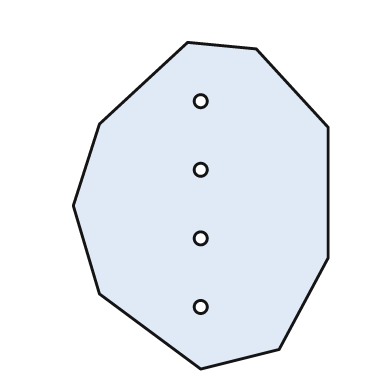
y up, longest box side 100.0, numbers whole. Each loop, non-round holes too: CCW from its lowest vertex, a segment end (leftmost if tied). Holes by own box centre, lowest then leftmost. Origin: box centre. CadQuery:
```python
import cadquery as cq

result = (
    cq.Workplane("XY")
    .moveTo(0.0, -50.0)
    .lineTo(24.0, -44.0)
    .lineTo(39.0, -16.0)
    .lineTo(39.0, 24.0)
    .lineTo(17.0, 48.0)
    .lineTo(-4.0, 50.0)
    .lineTo(-31.0, 25.0)
    .lineTo(-39.0, 0.0)
    .lineTo(-31.0, -27.0)
    .close()
    .moveTo(0.0, -31.0)
    .circle(2.0)
    .moveTo(0.0, -10.0)
    .circle(2.0)
    .moveTo(0.0, 11.0)
    .circle(2.0)
    .moveTo(0.0, 32.0)
    .circle(2.0)
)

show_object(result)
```